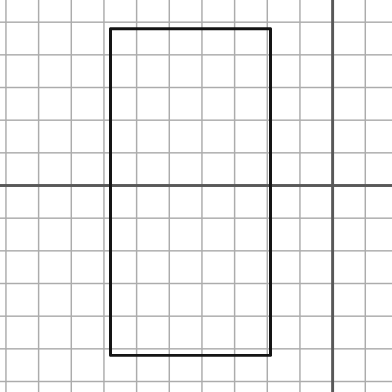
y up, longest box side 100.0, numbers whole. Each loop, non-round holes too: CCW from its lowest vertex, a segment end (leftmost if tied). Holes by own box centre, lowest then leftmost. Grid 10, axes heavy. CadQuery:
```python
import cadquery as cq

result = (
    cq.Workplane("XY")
    .moveTo(-68.0, -52.0)
    .lineTo(-19.0, -52.0)
    .lineTo(-19.0, 48.0)
    .lineTo(-68.0, 48.0)
    .close()
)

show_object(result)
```